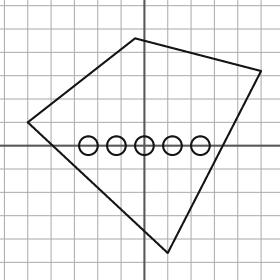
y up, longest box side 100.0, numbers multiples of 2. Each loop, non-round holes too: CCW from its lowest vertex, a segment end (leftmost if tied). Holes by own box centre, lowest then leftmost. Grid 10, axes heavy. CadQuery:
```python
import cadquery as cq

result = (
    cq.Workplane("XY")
    .moveTo(10.0, -46.0)
    .lineTo(50.0, 32.0)
    .lineTo(-4.0, 46.0)
    .lineTo(-50.0, 10.0)
    .close()
    .moveTo(-24.0, 0.0)
    .circle(4.0)
    .moveTo(-12.0, 0.0)
    .circle(4.0)
    .moveTo(0.0, 0.0)
    .circle(4.0)
    .moveTo(12.0, 0.0)
    .circle(4.0)
    .moveTo(24.0, 0.0)
    .circle(4.0)
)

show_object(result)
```